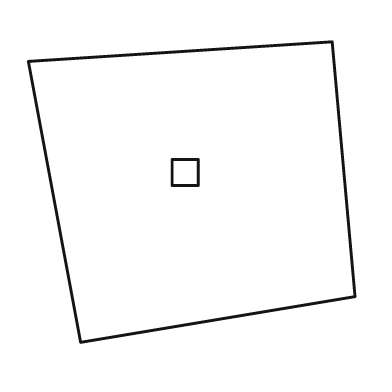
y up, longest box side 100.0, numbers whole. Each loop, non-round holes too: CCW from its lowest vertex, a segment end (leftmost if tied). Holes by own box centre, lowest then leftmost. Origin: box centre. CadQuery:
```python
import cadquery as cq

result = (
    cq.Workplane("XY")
    .moveTo(-34.0, -46.0)
    .lineTo(50.0, -32.0)
    .lineTo(43.0, 46.0)
    .lineTo(-50.0, 40.0)
    .close()
    .moveTo(-6.0, 2.0)
    .lineTo(2.0, 2.0)
    .lineTo(2.0, 10.0)
    .lineTo(-6.0, 10.0)
    .close()
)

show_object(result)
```